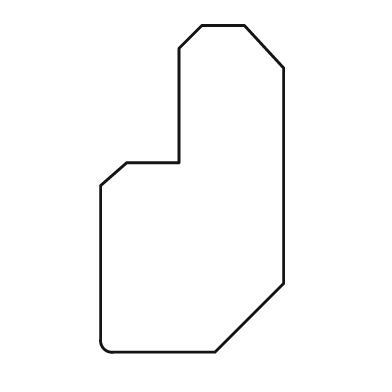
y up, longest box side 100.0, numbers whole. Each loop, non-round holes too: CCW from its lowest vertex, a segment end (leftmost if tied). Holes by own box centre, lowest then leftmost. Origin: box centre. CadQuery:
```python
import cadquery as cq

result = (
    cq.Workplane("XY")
    .moveTo(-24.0, -50.0)
    .lineTo(7.0, -50.0)
    .lineTo(28.0, -29.0)
    .lineTo(28.0, 37.0)
    .lineTo(16.0, 50.0)
    .lineTo(3.0, 50.0)
    .lineTo(-4.0, 43.0)
    .lineTo(-4.0, 8.0)
    .lineTo(-20.0, 8.0)
    .lineTo(-28.0, 1.0)
    .lineTo(-28.0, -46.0)
    .threePointArc((-27.0, -49.0), (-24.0, -50.0))
    .close()
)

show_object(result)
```